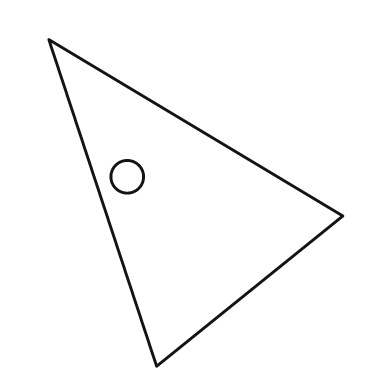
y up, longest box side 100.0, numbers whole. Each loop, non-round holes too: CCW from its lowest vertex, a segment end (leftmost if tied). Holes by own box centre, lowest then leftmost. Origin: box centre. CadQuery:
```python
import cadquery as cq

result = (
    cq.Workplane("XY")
    .moveTo(-12.0, -50.0)
    .lineTo(45.0, -4.0)
    .lineTo(-45.0, 50.0)
    .close()
    .moveTo(-21.0, 8.0)
    .circle(5.0)
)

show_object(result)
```